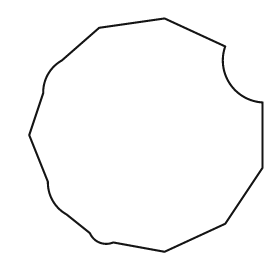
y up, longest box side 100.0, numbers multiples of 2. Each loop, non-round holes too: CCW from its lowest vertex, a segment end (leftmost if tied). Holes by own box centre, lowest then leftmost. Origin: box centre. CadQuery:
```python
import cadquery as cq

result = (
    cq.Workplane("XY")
    .moveTo(8.0, -50.0)
    .lineTo(34.0, -38.0)
    .lineTo(50.0, -14.0)
    .lineTo(50.0, 14.0)
    .threePointArc((36.0, 22.0), (34.0, 38.0))
    .lineTo(8.0, 50.0)
    .lineTo(-20.0, 46.0)
    .lineTo(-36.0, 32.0)
    .threePointArc((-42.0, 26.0), (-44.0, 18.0))
    .lineTo(-50.0, 0.0)
    .lineTo(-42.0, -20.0)
    .threePointArc((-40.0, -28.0), (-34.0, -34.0))
    .lineTo(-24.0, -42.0)
    .threePointArc((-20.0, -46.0), (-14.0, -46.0))
    .close()
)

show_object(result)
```